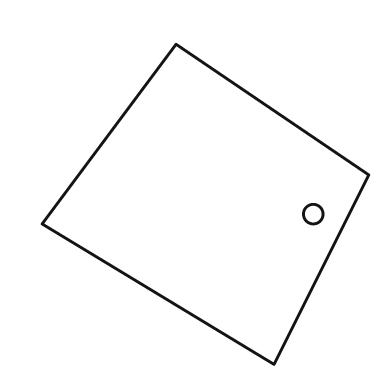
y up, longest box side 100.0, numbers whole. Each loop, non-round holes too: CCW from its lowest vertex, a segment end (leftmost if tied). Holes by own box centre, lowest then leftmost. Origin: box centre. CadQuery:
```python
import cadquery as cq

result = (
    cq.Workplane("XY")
    .moveTo(21.0, -49.0)
    .lineTo(50.0, 9.0)
    .lineTo(-9.0, 49.0)
    .lineTo(-50.0, -6.0)
    .close()
    .moveTo(33.0, -3.0)
    .circle(3.0)
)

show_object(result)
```